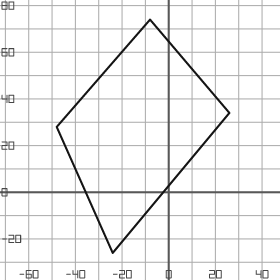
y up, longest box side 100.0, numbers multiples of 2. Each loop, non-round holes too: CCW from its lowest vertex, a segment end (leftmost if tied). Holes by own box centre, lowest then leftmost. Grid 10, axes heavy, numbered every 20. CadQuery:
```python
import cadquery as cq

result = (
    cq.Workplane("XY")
    .moveTo(-24.0, -26.0)
    .lineTo(26.0, 34.0)
    .lineTo(-8.0, 74.0)
    .lineTo(-48.0, 28.0)
    .close()
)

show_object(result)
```